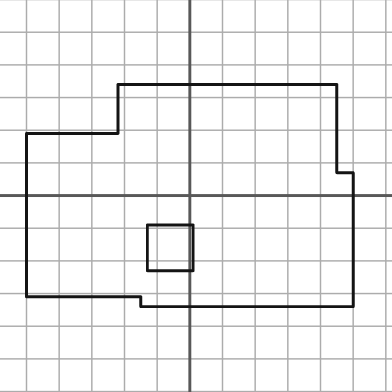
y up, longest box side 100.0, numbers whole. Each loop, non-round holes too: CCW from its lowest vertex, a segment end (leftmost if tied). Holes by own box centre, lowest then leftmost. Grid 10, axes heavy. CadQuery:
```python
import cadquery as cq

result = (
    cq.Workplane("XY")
    .moveTo(-15.0, -34.0)
    .lineTo(50.0, -34.0)
    .lineTo(50.0, 7.0)
    .lineTo(45.0, 7.0)
    .lineTo(45.0, 34.0)
    .lineTo(-22.0, 34.0)
    .lineTo(-22.0, 19.0)
    .lineTo(-50.0, 19.0)
    .lineTo(-50.0, -31.0)
    .lineTo(-15.0, -31.0)
    .close()
    .moveTo(-13.0, -23.0)
    .lineTo(1.0, -23.0)
    .lineTo(1.0, -9.0)
    .lineTo(-13.0, -9.0)
    .close()
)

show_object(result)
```